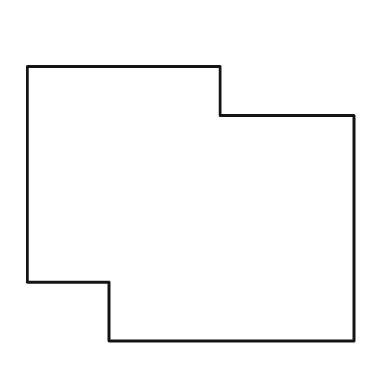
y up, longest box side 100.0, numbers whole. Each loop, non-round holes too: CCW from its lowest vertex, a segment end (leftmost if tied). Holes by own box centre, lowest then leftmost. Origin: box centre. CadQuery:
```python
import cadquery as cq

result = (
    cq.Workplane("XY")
    .moveTo(-25.0, -42.0)
    .lineTo(50.0, -42.0)
    .lineTo(50.0, 27.0)
    .lineTo(9.0, 27.0)
    .lineTo(9.0, 42.0)
    .lineTo(-50.0, 42.0)
    .lineTo(-50.0, -24.0)
    .lineTo(-25.0, -24.0)
    .close()
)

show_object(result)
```